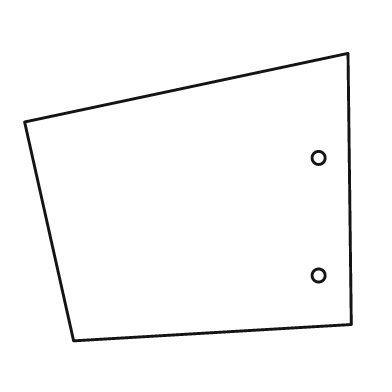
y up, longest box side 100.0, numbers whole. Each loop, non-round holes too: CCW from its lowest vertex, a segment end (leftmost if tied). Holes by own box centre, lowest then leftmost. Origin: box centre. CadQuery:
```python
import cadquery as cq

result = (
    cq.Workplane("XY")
    .moveTo(-35.0, -44.0)
    .lineTo(50.0, -39.0)
    .lineTo(49.0, 44.0)
    .lineTo(-50.0, 23.0)
    .close()
    .moveTo(40.0, -24.0)
    .circle(2.0)
    .moveTo(40.0, 12.0)
    .circle(2.0)
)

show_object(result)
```